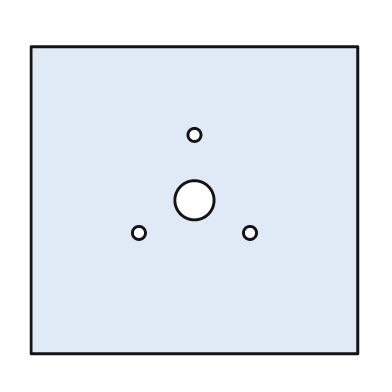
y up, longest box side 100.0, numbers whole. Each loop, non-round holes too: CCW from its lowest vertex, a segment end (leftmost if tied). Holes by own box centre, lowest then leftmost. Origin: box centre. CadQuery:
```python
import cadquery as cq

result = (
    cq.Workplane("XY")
    .moveTo(-50.0, -47.0)
    .lineTo(50.0, -47.0)
    .lineTo(50.0, 47.0)
    .lineTo(-50.0, 47.0)
    .close()
    .moveTo(-17.0, -10.0)
    .circle(2.0)
    .moveTo(17.0, -10.0)
    .circle(2.0)
    .moveTo(0.0, 0.0)
    .circle(6.0)
    .moveTo(0.0, 20.0)
    .circle(2.0)
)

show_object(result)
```